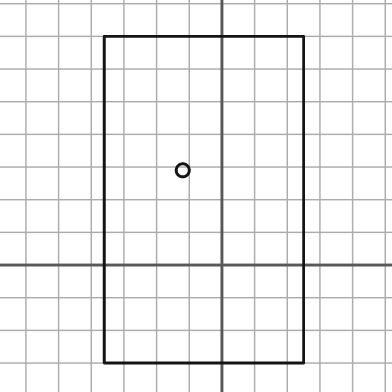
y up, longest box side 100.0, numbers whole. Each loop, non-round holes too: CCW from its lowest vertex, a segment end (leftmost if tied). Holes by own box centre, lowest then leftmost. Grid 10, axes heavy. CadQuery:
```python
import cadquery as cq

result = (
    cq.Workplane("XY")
    .moveTo(-36.0, -30.0)
    .lineTo(25.0, -30.0)
    .lineTo(25.0, 70.0)
    .lineTo(-36.0, 70.0)
    .close()
    .moveTo(-12.0, 29.0)
    .circle(2.0)
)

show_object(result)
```